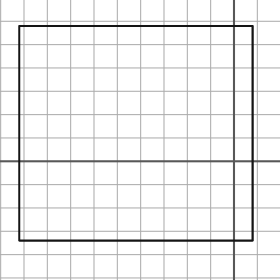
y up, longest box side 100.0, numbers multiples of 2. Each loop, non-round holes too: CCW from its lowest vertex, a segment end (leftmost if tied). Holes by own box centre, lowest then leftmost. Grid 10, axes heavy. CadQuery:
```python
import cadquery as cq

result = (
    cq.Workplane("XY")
    .moveTo(-92.0, -34.0)
    .lineTo(8.0, -34.0)
    .lineTo(8.0, 58.0)
    .lineTo(-92.0, 58.0)
    .close()
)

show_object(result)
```